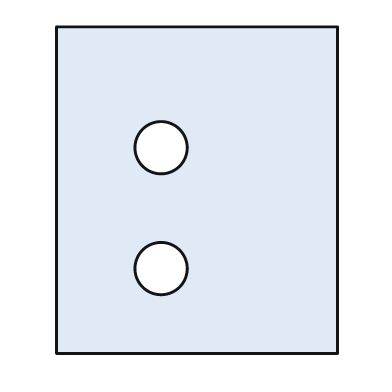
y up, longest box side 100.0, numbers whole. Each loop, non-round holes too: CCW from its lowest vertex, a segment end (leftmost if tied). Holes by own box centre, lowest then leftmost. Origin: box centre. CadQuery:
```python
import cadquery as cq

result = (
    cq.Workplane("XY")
    .moveTo(-43.0, -50.0)
    .lineTo(43.0, -50.0)
    .lineTo(43.0, 50.0)
    .lineTo(-43.0, 50.0)
    .close()
    .moveTo(-11.0, -24.0)
    .circle(8.0)
    .moveTo(-11.0, 13.0)
    .circle(8.0)
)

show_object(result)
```